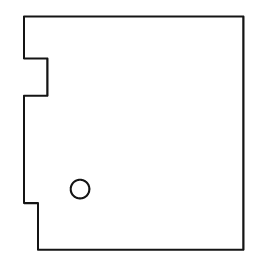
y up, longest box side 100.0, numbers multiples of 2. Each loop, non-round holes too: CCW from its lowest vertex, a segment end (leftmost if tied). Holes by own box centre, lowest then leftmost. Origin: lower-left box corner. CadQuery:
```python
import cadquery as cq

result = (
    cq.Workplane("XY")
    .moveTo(6.0, 0.0)
    .lineTo(94.0, 0.0)
    .lineTo(94.0, 100.0)
    .lineTo(0.0, 100.0)
    .lineTo(0.0, 82.0)
    .lineTo(10.0, 82.0)
    .lineTo(10.0, 66.0)
    .lineTo(0.0, 66.0)
    .lineTo(0.0, 20.0)
    .lineTo(6.0, 20.0)
    .close()
    .moveTo(24.0, 26.0)
    .circle(4.0)
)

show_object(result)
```